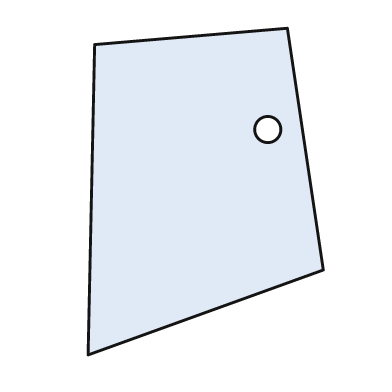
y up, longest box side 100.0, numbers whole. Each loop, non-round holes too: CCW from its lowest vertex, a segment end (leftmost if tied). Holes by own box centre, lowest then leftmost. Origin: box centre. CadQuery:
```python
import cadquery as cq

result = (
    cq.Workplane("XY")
    .moveTo(-36.0, -50.0)
    .lineTo(36.0, -24.0)
    .lineTo(25.0, 50.0)
    .lineTo(-34.0, 45.0)
    .close()
    .moveTo(19.0, 19.0)
    .circle(4.0)
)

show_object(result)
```